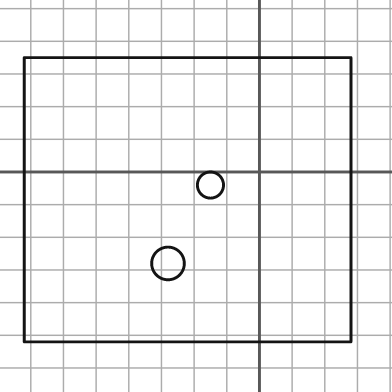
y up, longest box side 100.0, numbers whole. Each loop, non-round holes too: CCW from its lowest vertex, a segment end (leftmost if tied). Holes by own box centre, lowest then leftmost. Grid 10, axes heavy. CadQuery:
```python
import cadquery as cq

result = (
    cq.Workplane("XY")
    .moveTo(-72.0, -52.0)
    .lineTo(28.0, -52.0)
    .lineTo(28.0, 35.0)
    .lineTo(-72.0, 35.0)
    .close()
    .moveTo(-28.0, -28.0)
    .circle(5.0)
    .moveTo(-15.0, -4.0)
    .circle(4.0)
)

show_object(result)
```